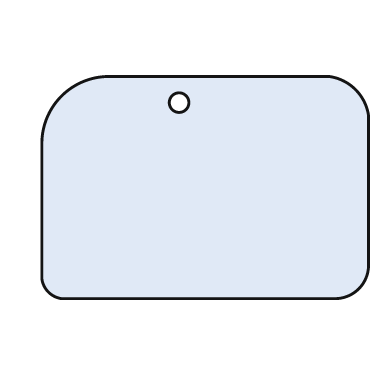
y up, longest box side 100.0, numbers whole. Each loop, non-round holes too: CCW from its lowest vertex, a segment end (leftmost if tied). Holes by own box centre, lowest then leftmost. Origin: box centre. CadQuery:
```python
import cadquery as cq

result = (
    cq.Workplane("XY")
    .moveTo(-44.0, -34.0)
    .lineTo(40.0, -34.0)
    .threePointArc((47.0, -31.0), (50.0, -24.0))
    .lineTo(50.0, 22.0)
    .threePointArc((46.0, 30.0), (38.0, 34.0))
    .lineTo(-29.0, 34.0)
    .threePointArc((-44.0, 28.0), (-50.0, 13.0))
    .lineTo(-50.0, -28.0)
    .threePointArc((-48.0, -32.0), (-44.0, -34.0))
    .close()
    .moveTo(-8.0, 26.0)
    .circle(3.0)
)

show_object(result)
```